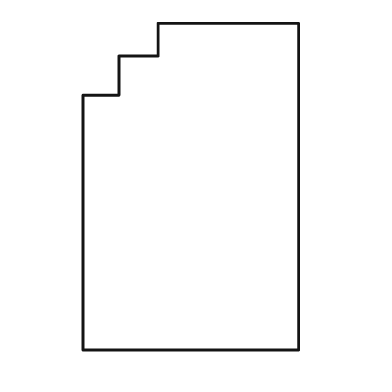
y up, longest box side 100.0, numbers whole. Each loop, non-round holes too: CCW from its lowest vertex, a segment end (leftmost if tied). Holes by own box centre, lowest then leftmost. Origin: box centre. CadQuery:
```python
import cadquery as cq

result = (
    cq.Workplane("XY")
    .moveTo(-33.0, -50.0)
    .lineTo(33.0, -50.0)
    .lineTo(33.0, 50.0)
    .lineTo(-10.0, 50.0)
    .lineTo(-10.0, 40.0)
    .lineTo(-22.0, 40.0)
    .lineTo(-22.0, 28.0)
    .lineTo(-33.0, 28.0)
    .close()
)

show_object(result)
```